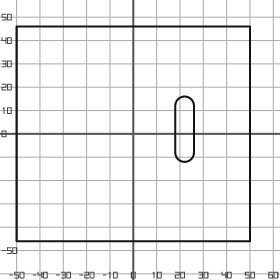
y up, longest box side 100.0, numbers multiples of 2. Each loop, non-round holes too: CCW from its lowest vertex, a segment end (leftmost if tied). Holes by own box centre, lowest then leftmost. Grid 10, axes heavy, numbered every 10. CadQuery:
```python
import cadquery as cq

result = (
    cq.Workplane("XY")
    .moveTo(-50.0, -46.0)
    .lineTo(50.0, -46.0)
    .lineTo(50.0, 46.0)
    .lineTo(-50.0, 46.0)
    .close()
    .moveTo(18.0, -8.0)
    .threePointArc((22.0, -12.0), (26.0, -8.0))
    .lineTo(26.0, 12.0)
    .threePointArc((22.0, 16.0), (18.0, 12.0))
    .close()
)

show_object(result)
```